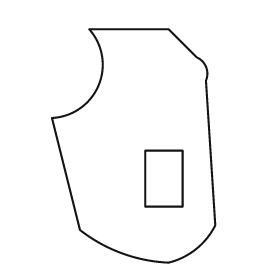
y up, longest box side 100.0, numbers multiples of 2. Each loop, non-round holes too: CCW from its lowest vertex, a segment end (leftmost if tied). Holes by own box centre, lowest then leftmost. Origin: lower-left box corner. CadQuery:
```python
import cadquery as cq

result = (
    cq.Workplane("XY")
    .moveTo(50.0, 0.0)
    .threePointArc((62.0, 6.0), (70.0, 16.0))
    .lineTo(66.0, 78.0)
    .threePointArc((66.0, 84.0), (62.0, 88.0))
    .lineTo(50.0, 100.0)
    .lineTo(16.0, 100.0)
    .threePointArc((20.0, 76.0), (0.0, 62.0))
    .lineTo(12.0, 14.0)
    .threePointArc((30.0, 4.0), (50.0, 0.0))
    .close()
    .moveTo(40.0, 24.0)
    .lineTo(56.0, 24.0)
    .lineTo(56.0, 48.0)
    .lineTo(40.0, 48.0)
    .close()
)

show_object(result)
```